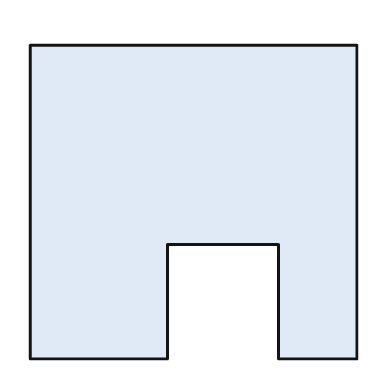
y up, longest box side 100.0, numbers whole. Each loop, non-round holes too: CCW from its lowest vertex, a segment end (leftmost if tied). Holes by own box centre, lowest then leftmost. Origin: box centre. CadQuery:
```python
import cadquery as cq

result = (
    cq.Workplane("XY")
    .moveTo(-50.0, -48.0)
    .lineTo(-8.0, -48.0)
    .lineTo(-8.0, -13.0)
    .lineTo(26.0, -13.0)
    .lineTo(26.0, -48.0)
    .lineTo(50.0, -48.0)
    .lineTo(50.0, 48.0)
    .lineTo(-50.0, 48.0)
    .close()
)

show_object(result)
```